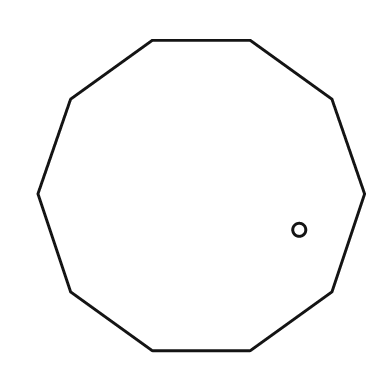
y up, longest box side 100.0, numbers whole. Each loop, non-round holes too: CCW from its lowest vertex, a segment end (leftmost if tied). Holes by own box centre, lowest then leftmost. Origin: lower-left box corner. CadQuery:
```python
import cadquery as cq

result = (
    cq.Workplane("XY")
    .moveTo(35.0, 0.0)
    .lineTo(65.0, 0.0)
    .lineTo(90.0, 18.0)
    .lineTo(100.0, 48.0)
    .lineTo(90.0, 77.0)
    .lineTo(65.0, 95.0)
    .lineTo(35.0, 95.0)
    .lineTo(10.0, 77.0)
    .lineTo(0.0, 48.0)
    .lineTo(10.0, 18.0)
    .close()
    .moveTo(80.0, 37.0)
    .circle(2.0)
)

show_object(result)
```